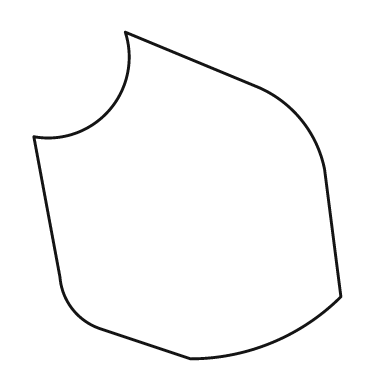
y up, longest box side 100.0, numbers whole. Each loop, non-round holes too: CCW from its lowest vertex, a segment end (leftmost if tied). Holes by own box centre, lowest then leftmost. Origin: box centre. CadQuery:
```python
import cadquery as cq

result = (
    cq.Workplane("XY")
    .moveTo(1.0, -50.0)
    .threePointArc((26.0, -45.0), (47.0, -31.0))
    .lineTo(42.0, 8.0)
    .threePointArc((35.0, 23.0), (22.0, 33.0))
    .lineTo(-19.0, 50.0)
    .threePointArc((-24.0, 26.0), (-47.0, 18.0))
    .lineTo(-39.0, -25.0)
    .threePointArc((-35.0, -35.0), (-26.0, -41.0))
    .close()
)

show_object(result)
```